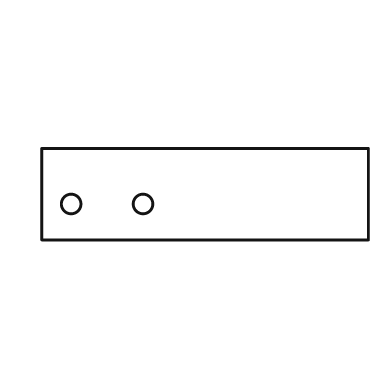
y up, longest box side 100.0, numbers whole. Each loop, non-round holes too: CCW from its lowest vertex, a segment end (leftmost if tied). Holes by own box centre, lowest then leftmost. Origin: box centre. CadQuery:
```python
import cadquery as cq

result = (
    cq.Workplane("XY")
    .moveTo(-50.0, -14.0)
    .lineTo(50.0, -14.0)
    .lineTo(50.0, 14.0)
    .lineTo(-50.0, 14.0)
    .close()
    .moveTo(-41.0, -3.0)
    .circle(3.0)
    .moveTo(-19.0, -3.0)
    .circle(3.0)
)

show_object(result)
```